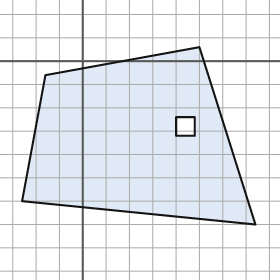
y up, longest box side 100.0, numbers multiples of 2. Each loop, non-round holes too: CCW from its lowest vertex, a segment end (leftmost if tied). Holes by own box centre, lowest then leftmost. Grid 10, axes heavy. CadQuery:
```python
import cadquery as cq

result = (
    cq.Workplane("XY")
    .moveTo(74.0, -70.0)
    .lineTo(50.0, 6.0)
    .lineTo(-16.0, -6.0)
    .lineTo(-26.0, -60.0)
    .close()
    .moveTo(40.0, -32.0)
    .lineTo(48.0, -32.0)
    .lineTo(48.0, -24.0)
    .lineTo(40.0, -24.0)
    .close()
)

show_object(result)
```